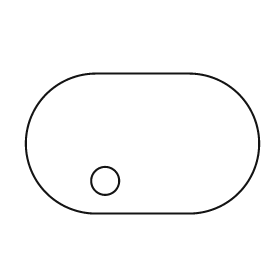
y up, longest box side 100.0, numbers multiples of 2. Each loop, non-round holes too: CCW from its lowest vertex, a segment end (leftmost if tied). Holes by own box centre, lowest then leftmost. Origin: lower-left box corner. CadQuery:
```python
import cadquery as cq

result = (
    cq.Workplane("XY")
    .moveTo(30.0, 0.0)
    .lineTo(70.0, 0.0)
    .threePointArc((100.0, 30.0), (70.0, 60.0))
    .lineTo(30.0, 60.0)
    .threePointArc((0.0, 30.0), (30.0, 0.0))
    .close()
    .moveTo(34.0, 14.0)
    .circle(6.0)
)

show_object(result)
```